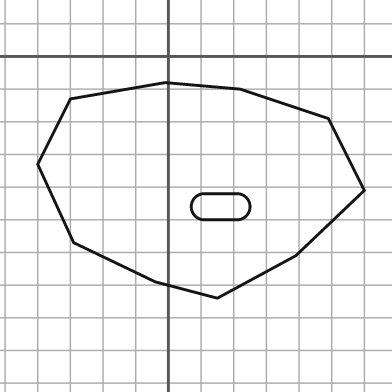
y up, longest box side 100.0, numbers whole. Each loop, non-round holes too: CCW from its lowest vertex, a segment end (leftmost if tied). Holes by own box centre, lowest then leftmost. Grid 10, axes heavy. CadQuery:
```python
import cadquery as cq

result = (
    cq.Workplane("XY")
    .moveTo(15.0, -74.0)
    .lineTo(39.0, -61.0)
    .lineTo(60.0, -41.0)
    .lineTo(49.0, -19.0)
    .lineTo(22.0, -10.0)
    .lineTo(-1.0, -8.0)
    .lineTo(-30.0, -13.0)
    .lineTo(-40.0, -33.0)
    .lineTo(-29.0, -57.0)
    .lineTo(-4.0, -69.0)
    .close()
    .moveTo(11.0, -50.0)
    .lineTo(21.0, -50.0)
    .threePointArc((25.0, -46.0), (21.0, -42.0))
    .lineTo(11.0, -42.0)
    .threePointArc((7.0, -46.0), (11.0, -50.0))
    .close()
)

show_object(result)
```